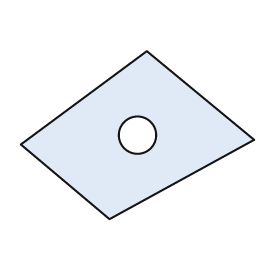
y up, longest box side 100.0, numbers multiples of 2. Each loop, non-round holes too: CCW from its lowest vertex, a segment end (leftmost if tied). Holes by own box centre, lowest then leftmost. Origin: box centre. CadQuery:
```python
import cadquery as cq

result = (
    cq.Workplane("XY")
    .moveTo(-12.0, -36.0)
    .lineTo(50.0, -2.0)
    .lineTo(4.0, 36.0)
    .lineTo(-50.0, -4.0)
    .close()
    .moveTo(0.0, 0.0)
    .circle(8.0)
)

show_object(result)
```